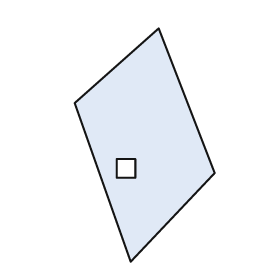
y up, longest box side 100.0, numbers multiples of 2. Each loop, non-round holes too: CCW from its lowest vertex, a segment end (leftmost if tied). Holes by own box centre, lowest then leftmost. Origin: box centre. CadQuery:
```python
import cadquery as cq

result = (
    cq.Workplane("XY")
    .moveTo(-6.0, -50.0)
    .lineTo(30.0, -12.0)
    .lineTo(6.0, 50.0)
    .lineTo(-30.0, 18.0)
    .close()
    .moveTo(-12.0, -14.0)
    .lineTo(-4.0, -14.0)
    .lineTo(-4.0, -6.0)
    .lineTo(-12.0, -6.0)
    .close()
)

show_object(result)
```